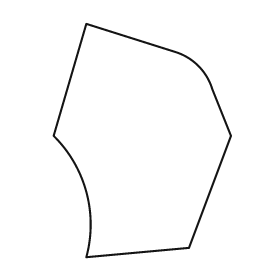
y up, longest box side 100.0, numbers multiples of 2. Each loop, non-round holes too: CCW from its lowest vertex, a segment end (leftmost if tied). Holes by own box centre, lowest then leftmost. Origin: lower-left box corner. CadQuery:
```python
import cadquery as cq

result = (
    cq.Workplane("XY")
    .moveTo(14.0, 0.0)
    .lineTo(58.0, 4.0)
    .lineTo(76.0, 52.0)
    .lineTo(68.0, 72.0)
    .threePointArc((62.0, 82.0), (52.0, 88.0))
    .lineTo(14.0, 100.0)
    .lineTo(0.0, 52.0)
    .threePointArc((14.0, 28.0), (14.0, 0.0))
    .close()
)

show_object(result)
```